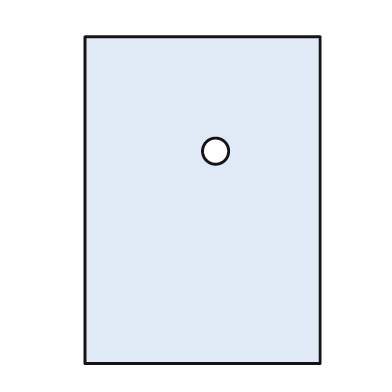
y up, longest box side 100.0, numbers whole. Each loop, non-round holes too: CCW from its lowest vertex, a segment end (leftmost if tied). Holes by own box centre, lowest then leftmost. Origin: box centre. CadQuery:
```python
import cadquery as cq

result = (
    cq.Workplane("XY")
    .moveTo(-36.0, -50.0)
    .lineTo(36.0, -50.0)
    .lineTo(36.0, 50.0)
    .lineTo(-36.0, 50.0)
    .close()
    .moveTo(4.0, 15.0)
    .circle(4.0)
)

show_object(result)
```